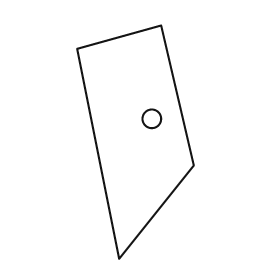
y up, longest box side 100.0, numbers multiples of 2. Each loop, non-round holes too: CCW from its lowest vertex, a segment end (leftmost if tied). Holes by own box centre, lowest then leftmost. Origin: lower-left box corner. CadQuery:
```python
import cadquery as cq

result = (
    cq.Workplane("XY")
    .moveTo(18.0, 0.0)
    .lineTo(50.0, 40.0)
    .lineTo(36.0, 100.0)
    .lineTo(0.0, 90.0)
    .close()
    .moveTo(32.0, 60.0)
    .circle(4.0)
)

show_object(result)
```